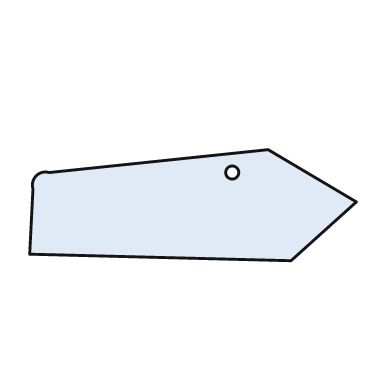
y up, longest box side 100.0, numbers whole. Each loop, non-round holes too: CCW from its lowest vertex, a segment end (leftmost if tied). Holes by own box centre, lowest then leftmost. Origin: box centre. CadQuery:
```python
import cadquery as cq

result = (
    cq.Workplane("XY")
    .moveTo(30.0, -17.0)
    .lineTo(50.0, 1.0)
    .lineTo(23.0, 17.0)
    .lineTo(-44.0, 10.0)
    .threePointArc((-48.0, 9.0), (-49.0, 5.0))
    .lineTo(-50.0, -15.0)
    .close()
    .moveTo(12.0, 10.0)
    .circle(2.0)
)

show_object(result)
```